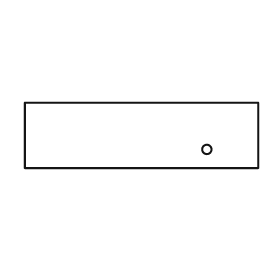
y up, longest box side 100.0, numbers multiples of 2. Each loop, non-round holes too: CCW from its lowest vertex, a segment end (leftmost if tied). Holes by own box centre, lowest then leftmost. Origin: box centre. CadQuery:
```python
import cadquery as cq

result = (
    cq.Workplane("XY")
    .moveTo(-50.0, -14.0)
    .lineTo(50.0, -14.0)
    .lineTo(50.0, 14.0)
    .lineTo(-50.0, 14.0)
    .close()
    .moveTo(28.0, -6.0)
    .circle(2.0)
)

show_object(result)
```